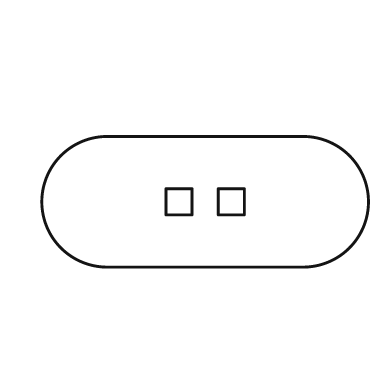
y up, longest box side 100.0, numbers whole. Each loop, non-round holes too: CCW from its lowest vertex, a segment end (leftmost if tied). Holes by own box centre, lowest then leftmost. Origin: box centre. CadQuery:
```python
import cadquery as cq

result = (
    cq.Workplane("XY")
    .moveTo(-30.0, -20.0)
    .lineTo(30.0, -20.0)
    .threePointArc((50.0, 0.0), (30.0, 20.0))
    .lineTo(-30.0, 20.0)
    .threePointArc((-50.0, 0.0), (-30.0, -20.0))
    .close()
    .moveTo(-12.0, -4.0)
    .lineTo(-4.0, -4.0)
    .lineTo(-4.0, 4.0)
    .lineTo(-12.0, 4.0)
    .close()
    .moveTo(4.0, -4.0)
    .lineTo(12.0, -4.0)
    .lineTo(12.0, 4.0)
    .lineTo(4.0, 4.0)
    .close()
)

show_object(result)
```